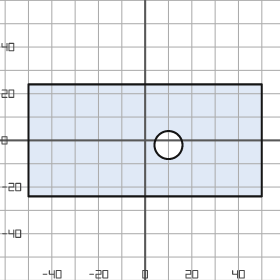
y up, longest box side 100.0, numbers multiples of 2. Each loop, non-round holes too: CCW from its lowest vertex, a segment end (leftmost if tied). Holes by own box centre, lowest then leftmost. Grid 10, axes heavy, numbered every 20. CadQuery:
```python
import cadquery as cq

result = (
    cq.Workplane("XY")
    .moveTo(-50.0, -24.0)
    .lineTo(50.0, -24.0)
    .lineTo(50.0, 24.0)
    .lineTo(-50.0, 24.0)
    .close()
    .moveTo(10.0, -2.0)
    .circle(6.0)
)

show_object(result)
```